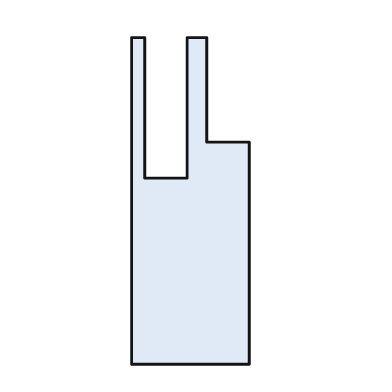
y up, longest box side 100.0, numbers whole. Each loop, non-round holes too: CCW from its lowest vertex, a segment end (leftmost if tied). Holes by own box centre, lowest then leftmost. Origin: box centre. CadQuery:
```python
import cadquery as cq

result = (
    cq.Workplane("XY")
    .moveTo(-18.0, -50.0)
    .lineTo(18.0, -50.0)
    .lineTo(18.0, 18.0)
    .lineTo(5.0, 18.0)
    .lineTo(5.0, 50.0)
    .lineTo(-1.0, 50.0)
    .lineTo(-1.0, 7.0)
    .lineTo(-14.0, 7.0)
    .lineTo(-14.0, 50.0)
    .lineTo(-18.0, 50.0)
    .close()
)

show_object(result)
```